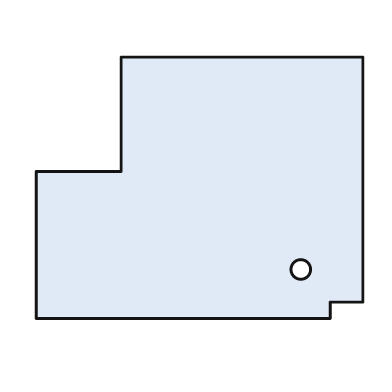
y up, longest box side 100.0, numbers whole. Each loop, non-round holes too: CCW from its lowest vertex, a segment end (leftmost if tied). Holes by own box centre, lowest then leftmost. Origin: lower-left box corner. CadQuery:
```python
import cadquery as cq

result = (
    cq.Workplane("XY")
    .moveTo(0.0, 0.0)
    .lineTo(90.0, 0.0)
    .lineTo(90.0, 5.0)
    .lineTo(100.0, 5.0)
    .lineTo(100.0, 80.0)
    .lineTo(26.0, 80.0)
    .lineTo(26.0, 45.0)
    .lineTo(0.0, 45.0)
    .close()
    .moveTo(81.0, 15.0)
    .circle(3.0)
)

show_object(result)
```